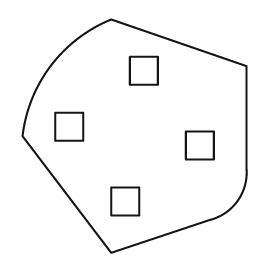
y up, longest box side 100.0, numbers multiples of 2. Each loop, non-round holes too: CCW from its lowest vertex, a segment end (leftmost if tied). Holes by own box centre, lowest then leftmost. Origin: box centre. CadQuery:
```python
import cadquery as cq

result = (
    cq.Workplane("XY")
    .moveTo(-10.0, -50.0)
    .lineTo(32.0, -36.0)
    .threePointArc((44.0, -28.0), (48.0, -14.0))
    .lineTo(48.0, 30.0)
    .lineTo(-10.0, 50.0)
    .threePointArc((-36.0, 30.0), (-48.0, 0.0))
    .close()
    .moveTo(-10.0, -34.0)
    .lineTo(2.0, -34.0)
    .lineTo(2.0, -22.0)
    .lineTo(-10.0, -22.0)
    .close()
    .moveTo(22.0, -10.0)
    .lineTo(34.0, -10.0)
    .lineTo(34.0, 2.0)
    .lineTo(22.0, 2.0)
    .close()
    .moveTo(-34.0, -2.0)
    .lineTo(-22.0, -2.0)
    .lineTo(-22.0, 10.0)
    .lineTo(-34.0, 10.0)
    .close()
    .moveTo(-2.0, 22.0)
    .lineTo(10.0, 22.0)
    .lineTo(10.0, 34.0)
    .lineTo(-2.0, 34.0)
    .close()
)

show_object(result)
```